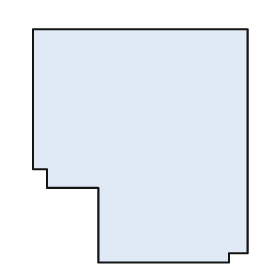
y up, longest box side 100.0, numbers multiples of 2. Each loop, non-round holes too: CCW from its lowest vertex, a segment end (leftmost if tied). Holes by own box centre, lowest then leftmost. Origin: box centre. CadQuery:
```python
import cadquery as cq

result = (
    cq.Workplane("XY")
    .moveTo(-18.0, -50.0)
    .lineTo(38.0, -50.0)
    .lineTo(38.0, -46.0)
    .lineTo(46.0, -46.0)
    .lineTo(46.0, 50.0)
    .lineTo(-46.0, 50.0)
    .lineTo(-46.0, -10.0)
    .lineTo(-40.0, -10.0)
    .lineTo(-40.0, -18.0)
    .lineTo(-18.0, -18.0)
    .close()
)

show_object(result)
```